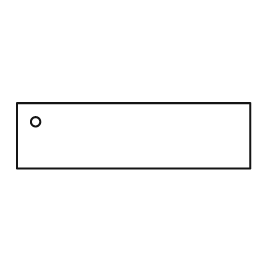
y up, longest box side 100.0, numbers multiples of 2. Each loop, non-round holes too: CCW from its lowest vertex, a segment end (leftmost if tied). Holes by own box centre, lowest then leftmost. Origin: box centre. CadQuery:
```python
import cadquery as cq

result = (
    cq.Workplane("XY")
    .moveTo(-50.0, -14.0)
    .lineTo(50.0, -14.0)
    .lineTo(50.0, 14.0)
    .lineTo(-50.0, 14.0)
    .close()
    .moveTo(-42.0, 6.0)
    .circle(2.0)
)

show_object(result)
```